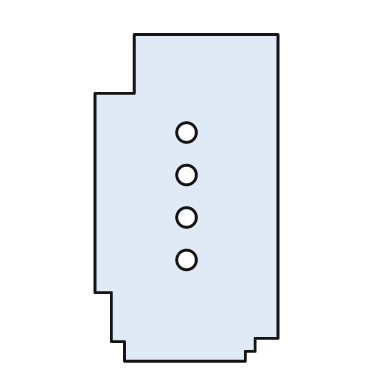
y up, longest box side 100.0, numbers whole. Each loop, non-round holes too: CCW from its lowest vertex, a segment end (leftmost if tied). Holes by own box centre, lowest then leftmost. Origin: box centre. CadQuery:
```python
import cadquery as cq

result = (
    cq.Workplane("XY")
    .moveTo(-19.0, -50.0)
    .lineTo(18.0, -50.0)
    .lineTo(18.0, -47.0)
    .lineTo(21.0, -47.0)
    .lineTo(21.0, -43.0)
    .lineTo(28.0, -43.0)
    .lineTo(28.0, 50.0)
    .lineTo(-16.0, 50.0)
    .lineTo(-16.0, 32.0)
    .lineTo(-28.0, 32.0)
    .lineTo(-28.0, -29.0)
    .lineTo(-23.0, -29.0)
    .lineTo(-23.0, -44.0)
    .lineTo(-19.0, -44.0)
    .close()
    .moveTo(0.0, -19.0)
    .circle(3.0)
    .moveTo(0.0, -6.0)
    .circle(3.0)
    .moveTo(0.0, 7.0)
    .circle(3.0)
    .moveTo(0.0, 20.0)
    .circle(3.0)
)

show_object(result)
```